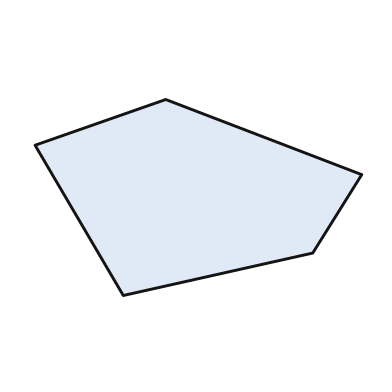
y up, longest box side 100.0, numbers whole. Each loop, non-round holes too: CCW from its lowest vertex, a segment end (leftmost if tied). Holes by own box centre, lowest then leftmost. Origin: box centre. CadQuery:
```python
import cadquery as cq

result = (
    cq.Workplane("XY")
    .moveTo(-23.0, -30.0)
    .lineTo(35.0, -17.0)
    .lineTo(50.0, 7.0)
    .lineTo(-10.0, 30.0)
    .lineTo(-50.0, 16.0)
    .close()
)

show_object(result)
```